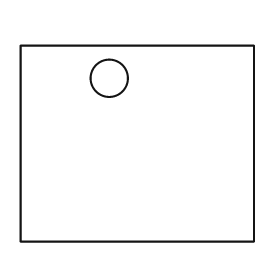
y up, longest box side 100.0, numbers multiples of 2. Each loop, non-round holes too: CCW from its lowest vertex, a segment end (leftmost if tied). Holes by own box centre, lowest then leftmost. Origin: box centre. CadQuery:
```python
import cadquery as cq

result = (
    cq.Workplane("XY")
    .moveTo(-50.0, -42.0)
    .lineTo(50.0, -42.0)
    .lineTo(50.0, 42.0)
    .lineTo(-50.0, 42.0)
    .close()
    .moveTo(-12.0, 28.0)
    .circle(8.0)
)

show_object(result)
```